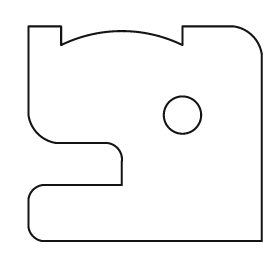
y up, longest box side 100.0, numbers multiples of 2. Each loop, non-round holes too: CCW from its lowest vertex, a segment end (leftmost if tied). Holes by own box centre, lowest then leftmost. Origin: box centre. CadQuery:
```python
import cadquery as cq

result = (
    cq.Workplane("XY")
    .moveTo(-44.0, -46.0)
    .lineTo(50.0, -46.0)
    .lineTo(50.0, 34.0)
    .threePointArc((46.0, 42.0), (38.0, 46.0))
    .lineTo(16.0, 46.0)
    .lineTo(16.0, 38.0)
    .threePointArc((-10.0, 44.0), (-36.0, 38.0))
    .lineTo(-36.0, 46.0)
    .lineTo(-50.0, 46.0)
    .lineTo(-50.0, 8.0)
    .threePointArc((-46.0, 0.0), (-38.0, -4.0))
    .lineTo(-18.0, -4.0)
    .threePointArc((-12.0, -6.0), (-10.0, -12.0))
    .lineTo(-10.0, -22.0)
    .lineTo(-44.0, -22.0)
    .threePointArc((-48.0, -24.0), (-50.0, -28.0))
    .lineTo(-50.0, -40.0)
    .threePointArc((-48.0, -44.0), (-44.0, -46.0))
    .close()
    .moveTo(16.0, 8.0)
    .circle(8.0)
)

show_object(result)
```